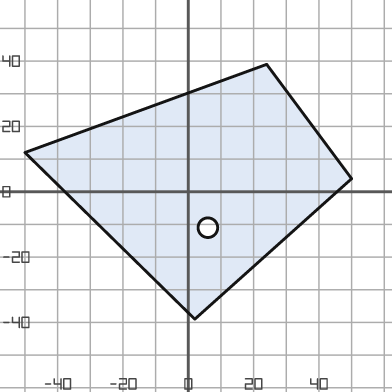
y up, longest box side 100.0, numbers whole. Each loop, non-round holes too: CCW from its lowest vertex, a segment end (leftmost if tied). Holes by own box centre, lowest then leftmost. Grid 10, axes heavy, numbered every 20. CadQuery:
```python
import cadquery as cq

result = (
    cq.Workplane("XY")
    .moveTo(2.0, -39.0)
    .lineTo(50.0, 4.0)
    .lineTo(24.0, 39.0)
    .lineTo(-50.0, 12.0)
    .close()
    .moveTo(6.0, -11.0)
    .circle(3.0)
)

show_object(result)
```